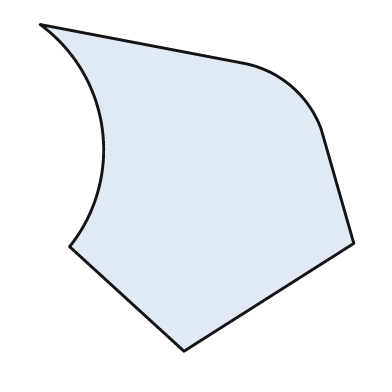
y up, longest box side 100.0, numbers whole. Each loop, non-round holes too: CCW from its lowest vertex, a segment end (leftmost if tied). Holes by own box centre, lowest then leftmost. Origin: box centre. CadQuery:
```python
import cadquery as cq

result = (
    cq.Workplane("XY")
    .moveTo(-4.0, -50.0)
    .lineTo(48.0, -17.0)
    .lineTo(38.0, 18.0)
    .threePointArc((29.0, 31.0), (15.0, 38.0))
    .lineTo(-48.0, 50.0)
    .threePointArc((-29.0, 18.0), (-39.0, -18.0))
    .close()
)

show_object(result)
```